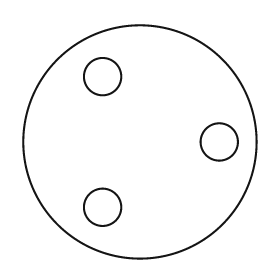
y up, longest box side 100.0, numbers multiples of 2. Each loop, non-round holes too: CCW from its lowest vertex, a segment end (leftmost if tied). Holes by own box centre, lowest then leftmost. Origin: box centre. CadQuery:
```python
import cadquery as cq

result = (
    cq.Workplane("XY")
    .moveTo(0.0, 0.0)
    .circle(50.0)
    .moveTo(-16.0, -28.0)
    .circle(8.0)
    .moveTo(34.0, 0.0)
    .circle(8.0)
    .moveTo(-16.0, 28.0)
    .circle(8.0)
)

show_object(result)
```